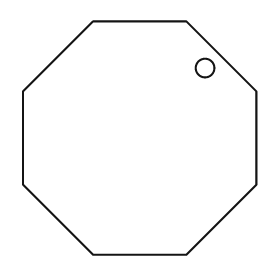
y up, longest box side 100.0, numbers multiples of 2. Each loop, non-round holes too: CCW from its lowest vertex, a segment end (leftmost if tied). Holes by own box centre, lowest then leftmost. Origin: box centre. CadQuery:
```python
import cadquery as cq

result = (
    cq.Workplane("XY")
    .moveTo(-20.0, -50.0)
    .lineTo(20.0, -50.0)
    .lineTo(50.0, -20.0)
    .lineTo(50.0, 20.0)
    .lineTo(20.0, 50.0)
    .lineTo(-20.0, 50.0)
    .lineTo(-50.0, 20.0)
    .lineTo(-50.0, -20.0)
    .close()
    .moveTo(28.0, 30.0)
    .circle(4.0)
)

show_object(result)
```